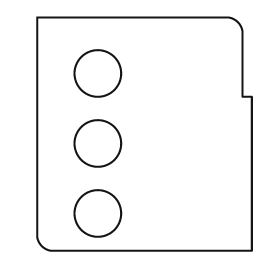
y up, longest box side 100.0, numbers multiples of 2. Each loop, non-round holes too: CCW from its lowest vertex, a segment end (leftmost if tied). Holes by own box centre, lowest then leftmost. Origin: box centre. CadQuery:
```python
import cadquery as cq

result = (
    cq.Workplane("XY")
    .moveTo(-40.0, -50.0)
    .lineTo(46.0, -50.0)
    .lineTo(46.0, 16.0)
    .lineTo(42.0, 16.0)
    .lineTo(42.0, 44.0)
    .threePointArc((40.0, 48.0), (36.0, 50.0))
    .lineTo(-46.0, 50.0)
    .lineTo(-46.0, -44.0)
    .threePointArc((-44.0, -48.0), (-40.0, -50.0))
    .close()
    .moveTo(-20.0, -34.0)
    .circle(10.0)
    .moveTo(-20.0, -4.0)
    .circle(10.0)
    .moveTo(-20.0, 26.0)
    .circle(10.0)
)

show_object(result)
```